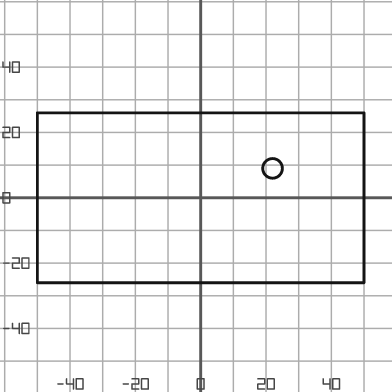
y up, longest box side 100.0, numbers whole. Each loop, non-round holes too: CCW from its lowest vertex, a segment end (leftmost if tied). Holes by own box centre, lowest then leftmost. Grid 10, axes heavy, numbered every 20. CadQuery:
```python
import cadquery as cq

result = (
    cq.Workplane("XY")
    .moveTo(-50.0, -26.0)
    .lineTo(50.0, -26.0)
    .lineTo(50.0, 26.0)
    .lineTo(-50.0, 26.0)
    .close()
    .moveTo(22.0, 9.0)
    .circle(3.0)
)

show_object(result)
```